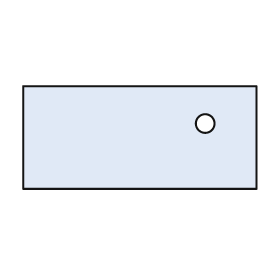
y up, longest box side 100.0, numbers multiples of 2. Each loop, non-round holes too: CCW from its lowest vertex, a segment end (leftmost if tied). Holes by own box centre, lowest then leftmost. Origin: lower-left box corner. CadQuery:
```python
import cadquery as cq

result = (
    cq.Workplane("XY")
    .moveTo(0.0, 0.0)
    .lineTo(100.0, 0.0)
    .lineTo(100.0, 44.0)
    .lineTo(0.0, 44.0)
    .close()
    .moveTo(78.0, 28.0)
    .circle(4.0)
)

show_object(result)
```